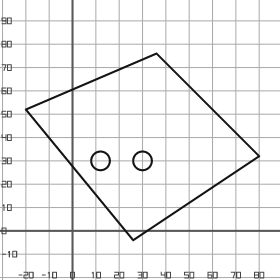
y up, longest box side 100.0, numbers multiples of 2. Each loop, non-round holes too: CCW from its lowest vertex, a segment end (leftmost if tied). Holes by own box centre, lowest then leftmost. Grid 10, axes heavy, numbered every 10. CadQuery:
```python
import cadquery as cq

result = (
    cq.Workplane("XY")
    .moveTo(26.0, -4.0)
    .lineTo(80.0, 32.0)
    .lineTo(36.0, 76.0)
    .lineTo(-20.0, 52.0)
    .close()
    .moveTo(12.0, 30.0)
    .circle(4.0)
    .moveTo(30.0, 30.0)
    .circle(4.0)
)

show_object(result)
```